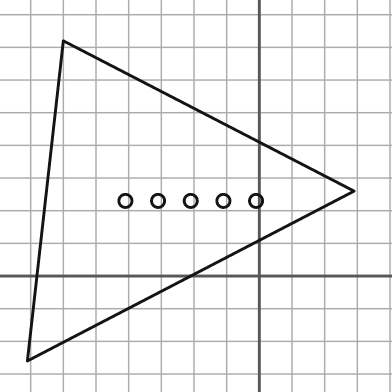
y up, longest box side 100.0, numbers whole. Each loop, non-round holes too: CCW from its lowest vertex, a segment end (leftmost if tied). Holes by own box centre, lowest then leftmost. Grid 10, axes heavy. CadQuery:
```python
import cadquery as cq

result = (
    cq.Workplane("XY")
    .moveTo(-71.0, -26.0)
    .lineTo(29.0, 26.0)
    .lineTo(-60.0, 72.0)
    .close()
    .moveTo(-41.0, 23.0)
    .circle(2.0)
    .moveTo(-31.0, 23.0)
    .circle(2.0)
    .moveTo(-21.0, 23.0)
    .circle(2.0)
    .moveTo(-11.0, 23.0)
    .circle(2.0)
    .moveTo(-1.0, 23.0)
    .circle(2.0)
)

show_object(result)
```